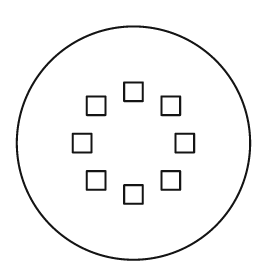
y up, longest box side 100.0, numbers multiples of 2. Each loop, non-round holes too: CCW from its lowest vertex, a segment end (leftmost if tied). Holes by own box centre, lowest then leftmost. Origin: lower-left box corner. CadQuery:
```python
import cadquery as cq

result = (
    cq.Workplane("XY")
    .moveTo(50.0, 50.0)
    .circle(50.0)
    .moveTo(46.0, 24.0)
    .lineTo(54.0, 24.0)
    .lineTo(54.0, 32.0)
    .lineTo(46.0, 32.0)
    .close()
    .moveTo(30.0, 30.0)
    .lineTo(38.0, 30.0)
    .lineTo(38.0, 38.0)
    .lineTo(30.0, 38.0)
    .close()
    .moveTo(62.0, 30.0)
    .lineTo(70.0, 30.0)
    .lineTo(70.0, 38.0)
    .lineTo(62.0, 38.0)
    .close()
    .moveTo(24.0, 46.0)
    .lineTo(32.0, 46.0)
    .lineTo(32.0, 54.0)
    .lineTo(24.0, 54.0)
    .close()
    .moveTo(68.0, 46.0)
    .lineTo(76.0, 46.0)
    .lineTo(76.0, 54.0)
    .lineTo(68.0, 54.0)
    .close()
    .moveTo(30.0, 62.0)
    .lineTo(38.0, 62.0)
    .lineTo(38.0, 70.0)
    .lineTo(30.0, 70.0)
    .close()
    .moveTo(62.0, 62.0)
    .lineTo(70.0, 62.0)
    .lineTo(70.0, 70.0)
    .lineTo(62.0, 70.0)
    .close()
    .moveTo(46.0, 68.0)
    .lineTo(54.0, 68.0)
    .lineTo(54.0, 76.0)
    .lineTo(46.0, 76.0)
    .close()
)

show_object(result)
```